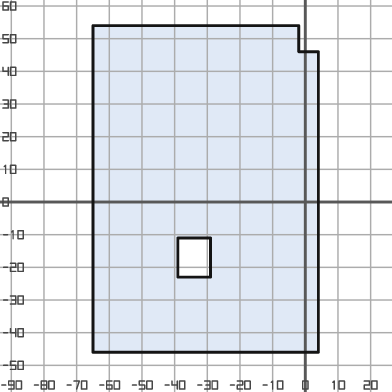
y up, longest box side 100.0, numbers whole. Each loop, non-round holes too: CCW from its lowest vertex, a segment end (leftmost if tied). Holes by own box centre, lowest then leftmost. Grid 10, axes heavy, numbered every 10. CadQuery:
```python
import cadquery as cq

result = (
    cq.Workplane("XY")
    .moveTo(-65.0, -46.0)
    .lineTo(4.0, -46.0)
    .lineTo(4.0, 46.0)
    .lineTo(-2.0, 46.0)
    .lineTo(-2.0, 54.0)
    .lineTo(-65.0, 54.0)
    .close()
    .moveTo(-39.0, -23.0)
    .lineTo(-29.0, -23.0)
    .lineTo(-29.0, -11.0)
    .lineTo(-39.0, -11.0)
    .close()
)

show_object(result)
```